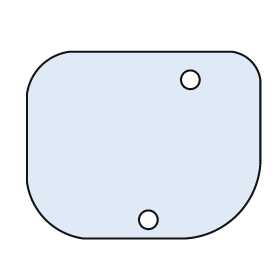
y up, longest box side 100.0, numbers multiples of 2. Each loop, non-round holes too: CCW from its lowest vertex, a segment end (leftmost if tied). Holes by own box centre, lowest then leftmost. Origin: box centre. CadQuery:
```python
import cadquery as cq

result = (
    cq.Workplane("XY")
    .moveTo(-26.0, -40.0)
    .lineTo(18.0, -40.0)
    .threePointArc((40.0, -30.0), (50.0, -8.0))
    .lineTo(50.0, 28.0)
    .threePointArc((46.0, 36.0), (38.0, 40.0))
    .lineTo(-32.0, 40.0)
    .threePointArc((-44.0, 34.0), (-50.0, 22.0))
    .lineTo(-50.0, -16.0)
    .threePointArc((-42.0, -32.0), (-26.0, -40.0))
    .close()
    .moveTo(2.0, -32.0)
    .circle(4.0)
    .moveTo(20.0, 28.0)
    .circle(4.0)
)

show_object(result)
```